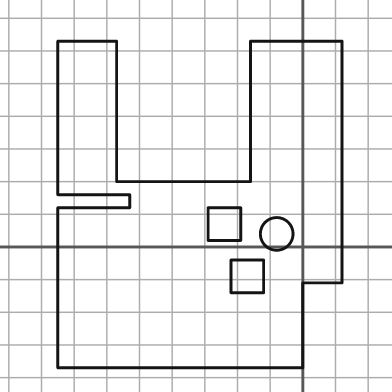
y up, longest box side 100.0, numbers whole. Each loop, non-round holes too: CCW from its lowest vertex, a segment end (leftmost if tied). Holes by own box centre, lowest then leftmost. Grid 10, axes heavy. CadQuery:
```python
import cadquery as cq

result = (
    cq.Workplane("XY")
    .moveTo(-75.0, -37.0)
    .lineTo(0.0, -37.0)
    .lineTo(0.0, -11.0)
    .lineTo(12.0, -11.0)
    .lineTo(12.0, 63.0)
    .lineTo(-16.0, 63.0)
    .lineTo(-16.0, 20.0)
    .lineTo(-57.0, 20.0)
    .lineTo(-57.0, 63.0)
    .lineTo(-75.0, 63.0)
    .lineTo(-75.0, 16.0)
    .lineTo(-53.0, 16.0)
    .lineTo(-53.0, 12.0)
    .lineTo(-75.0, 12.0)
    .close()
    .moveTo(-22.0, -14.0)
    .lineTo(-12.0, -14.0)
    .lineTo(-12.0, -4.0)
    .lineTo(-22.0, -4.0)
    .close()
    .moveTo(-8.0, 4.0)
    .circle(5.0)
    .moveTo(-29.0, 2.0)
    .lineTo(-19.0, 2.0)
    .lineTo(-19.0, 12.0)
    .lineTo(-29.0, 12.0)
    .close()
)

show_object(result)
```